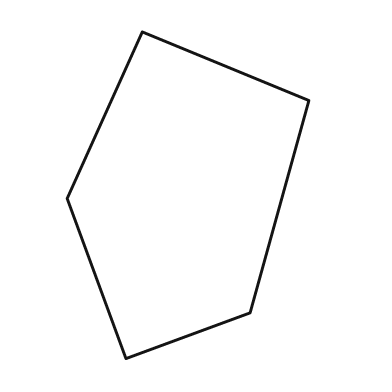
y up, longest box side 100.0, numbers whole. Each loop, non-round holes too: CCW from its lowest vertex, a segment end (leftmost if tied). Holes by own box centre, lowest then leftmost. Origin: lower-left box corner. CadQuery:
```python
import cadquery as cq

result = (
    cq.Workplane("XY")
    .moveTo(18.0, 0.0)
    .lineTo(56.0, 14.0)
    .lineTo(74.0, 79.0)
    .lineTo(23.0, 100.0)
    .lineTo(0.0, 49.0)
    .close()
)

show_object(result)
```